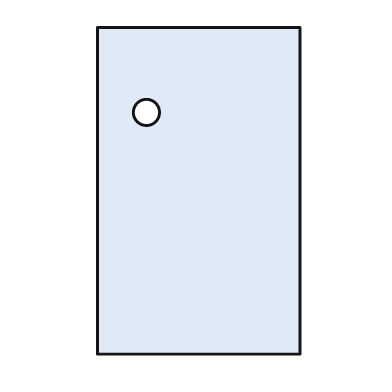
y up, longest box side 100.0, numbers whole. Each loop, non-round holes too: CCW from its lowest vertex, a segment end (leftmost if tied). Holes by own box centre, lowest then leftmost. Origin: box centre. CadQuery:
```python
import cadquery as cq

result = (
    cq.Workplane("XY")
    .moveTo(-31.0, -50.0)
    .lineTo(31.0, -50.0)
    .lineTo(31.0, 50.0)
    .lineTo(-31.0, 50.0)
    .close()
    .moveTo(-16.0, 24.0)
    .circle(4.0)
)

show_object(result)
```